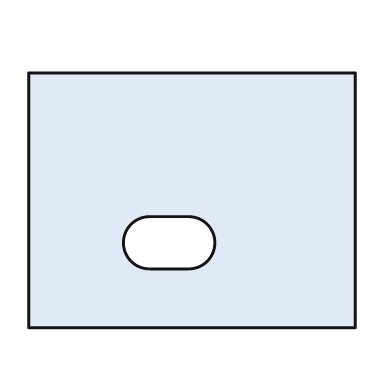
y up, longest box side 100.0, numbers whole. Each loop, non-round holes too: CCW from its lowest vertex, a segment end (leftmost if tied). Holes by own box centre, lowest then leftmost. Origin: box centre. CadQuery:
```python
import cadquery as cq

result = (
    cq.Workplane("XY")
    .moveTo(-50.0, -39.0)
    .lineTo(50.0, -39.0)
    .lineTo(50.0, 39.0)
    .lineTo(-50.0, 39.0)
    .close()
    .moveTo(-13.0, -21.0)
    .lineTo(-1.0, -21.0)
    .threePointArc((7.0, -13.0), (-1.0, -5.0))
    .lineTo(-13.0, -5.0)
    .threePointArc((-21.0, -13.0), (-13.0, -21.0))
    .close()
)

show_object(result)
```